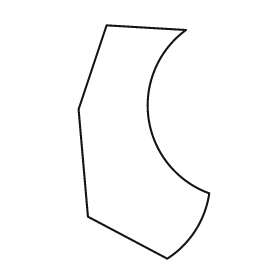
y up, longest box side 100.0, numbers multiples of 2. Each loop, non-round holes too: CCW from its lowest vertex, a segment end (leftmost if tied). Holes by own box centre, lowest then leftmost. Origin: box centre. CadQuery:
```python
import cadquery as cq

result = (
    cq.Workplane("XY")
    .moveTo(10.0, -50.0)
    .threePointArc((22.0, -38.0), (28.0, -22.0))
    .threePointArc((2.0, 10.0), (18.0, 48.0))
    .lineTo(-16.0, 50.0)
    .lineTo(-28.0, 14.0)
    .lineTo(-24.0, -32.0)
    .close()
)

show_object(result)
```